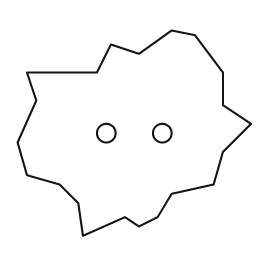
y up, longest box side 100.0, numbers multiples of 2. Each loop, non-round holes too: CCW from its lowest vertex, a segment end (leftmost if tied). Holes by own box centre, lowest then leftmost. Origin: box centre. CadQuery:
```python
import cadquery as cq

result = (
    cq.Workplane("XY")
    .moveTo(-22.0, -44.0)
    .lineTo(-4.0, -36.0)
    .lineTo(2.0, -40.0)
    .lineTo(10.0, -36.0)
    .lineTo(16.0, -26.0)
    .lineTo(34.0, -22.0)
    .lineTo(38.0, -8.0)
    .lineTo(50.0, 4.0)
    .lineTo(38.0, 12.0)
    .lineTo(38.0, 26.0)
    .lineTo(26.0, 42.0)
    .lineTo(16.0, 44.0)
    .lineTo(2.0, 34.0)
    .lineTo(-10.0, 38.0)
    .lineTo(-16.0, 26.0)
    .lineTo(-46.0, 26.0)
    .lineTo(-42.0, 14.0)
    .lineTo(-50.0, -4.0)
    .lineTo(-46.0, -18.0)
    .lineTo(-32.0, -22.0)
    .lineTo(-24.0, -30.0)
    .close()
    .moveTo(-12.0, 0.0)
    .circle(4.0)
    .moveTo(12.0, 0.0)
    .circle(4.0)
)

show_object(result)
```